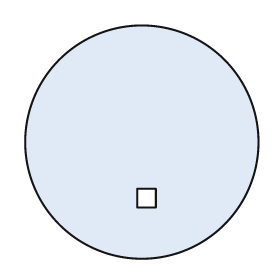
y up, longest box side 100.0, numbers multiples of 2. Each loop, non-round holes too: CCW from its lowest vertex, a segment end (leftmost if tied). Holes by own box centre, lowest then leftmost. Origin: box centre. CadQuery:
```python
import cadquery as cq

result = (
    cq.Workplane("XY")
    .moveTo(0.0, 0.0)
    .circle(50.0)
    .moveTo(-2.0, -28.0)
    .lineTo(6.0, -28.0)
    .lineTo(6.0, -20.0)
    .lineTo(-2.0, -20.0)
    .close()
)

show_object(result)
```